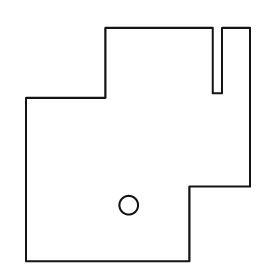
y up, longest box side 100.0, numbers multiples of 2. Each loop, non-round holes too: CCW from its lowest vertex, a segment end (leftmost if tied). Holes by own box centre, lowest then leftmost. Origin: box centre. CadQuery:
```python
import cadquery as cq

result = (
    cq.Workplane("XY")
    .moveTo(-48.0, -50.0)
    .lineTo(22.0, -50.0)
    .lineTo(22.0, -18.0)
    .lineTo(48.0, -18.0)
    .lineTo(48.0, 50.0)
    .lineTo(36.0, 50.0)
    .lineTo(36.0, 22.0)
    .lineTo(32.0, 22.0)
    .lineTo(32.0, 50.0)
    .lineTo(-14.0, 50.0)
    .lineTo(-14.0, 20.0)
    .lineTo(-48.0, 20.0)
    .close()
    .moveTo(-4.0, -26.0)
    .circle(4.0)
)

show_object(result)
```